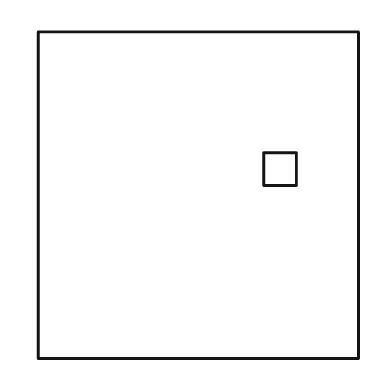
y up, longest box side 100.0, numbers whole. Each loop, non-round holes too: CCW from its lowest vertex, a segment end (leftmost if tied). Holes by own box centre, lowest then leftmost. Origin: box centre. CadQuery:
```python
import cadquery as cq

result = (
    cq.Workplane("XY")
    .moveTo(-49.0, -50.0)
    .lineTo(49.0, -50.0)
    .lineTo(49.0, 50.0)
    .lineTo(-49.0, 50.0)
    .close()
    .moveTo(20.0, 3.0)
    .lineTo(30.0, 3.0)
    .lineTo(30.0, 13.0)
    .lineTo(20.0, 13.0)
    .close()
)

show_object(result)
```